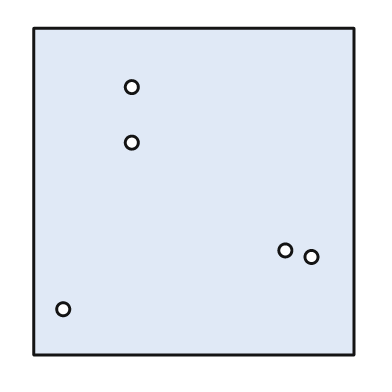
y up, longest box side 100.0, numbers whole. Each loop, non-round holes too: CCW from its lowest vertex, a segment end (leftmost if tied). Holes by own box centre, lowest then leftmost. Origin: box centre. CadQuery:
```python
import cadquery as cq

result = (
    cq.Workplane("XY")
    .moveTo(-49.0, -50.0)
    .lineTo(49.0, -50.0)
    .lineTo(49.0, 50.0)
    .lineTo(-49.0, 50.0)
    .close()
    .moveTo(-40.0, -36.0)
    .circle(2.0)
    .moveTo(36.0, -20.0)
    .circle(2.0)
    .moveTo(28.0, -18.0)
    .circle(2.0)
    .moveTo(-19.0, 15.0)
    .circle(2.0)
    .moveTo(-19.0, 32.0)
    .circle(2.0)
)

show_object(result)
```